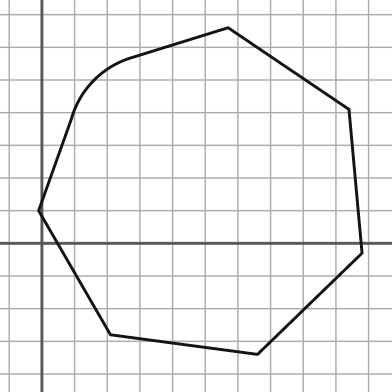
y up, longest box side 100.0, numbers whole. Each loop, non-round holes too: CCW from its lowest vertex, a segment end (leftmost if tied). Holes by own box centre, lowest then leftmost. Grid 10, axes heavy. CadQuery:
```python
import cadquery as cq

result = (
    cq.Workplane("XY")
    .moveTo(66.0, -34.0)
    .lineTo(98.0, -3.0)
    .lineTo(94.0, 41.0)
    .lineTo(57.0, 66.0)
    .lineTo(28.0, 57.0)
    .threePointArc((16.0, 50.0), (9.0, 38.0))
    .lineTo(-1.0, 10.0)
    .lineTo(21.0, -28.0)
    .close()
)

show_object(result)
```